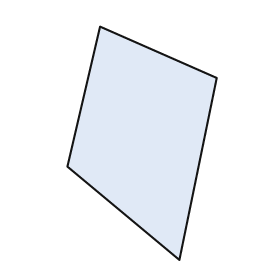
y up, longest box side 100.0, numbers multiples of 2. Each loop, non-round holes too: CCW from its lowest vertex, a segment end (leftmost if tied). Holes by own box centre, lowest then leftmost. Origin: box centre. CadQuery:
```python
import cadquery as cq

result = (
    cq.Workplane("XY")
    .moveTo(16.0, -50.0)
    .lineTo(32.0, 28.0)
    .lineTo(-18.0, 50.0)
    .lineTo(-32.0, -10.0)
    .close()
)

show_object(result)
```